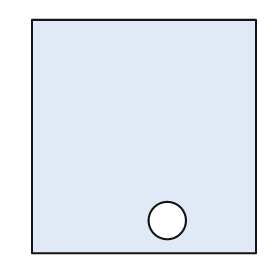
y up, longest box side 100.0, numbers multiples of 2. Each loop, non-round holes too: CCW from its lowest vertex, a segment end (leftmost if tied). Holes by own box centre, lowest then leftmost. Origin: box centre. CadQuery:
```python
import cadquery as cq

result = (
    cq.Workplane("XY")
    .moveTo(-48.0, -50.0)
    .lineTo(48.0, -50.0)
    .lineTo(48.0, 50.0)
    .lineTo(-48.0, 50.0)
    .close()
    .moveTo(10.0, -36.0)
    .circle(8.0)
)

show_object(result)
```